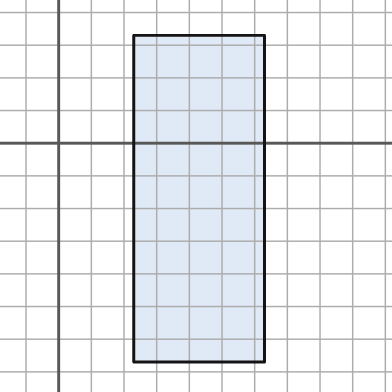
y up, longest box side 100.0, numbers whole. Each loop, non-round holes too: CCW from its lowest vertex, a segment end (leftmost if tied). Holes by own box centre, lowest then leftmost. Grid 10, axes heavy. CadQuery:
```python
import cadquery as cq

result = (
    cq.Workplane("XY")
    .moveTo(23.0, -67.0)
    .lineTo(63.0, -67.0)
    .lineTo(63.0, 33.0)
    .lineTo(23.0, 33.0)
    .close()
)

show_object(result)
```